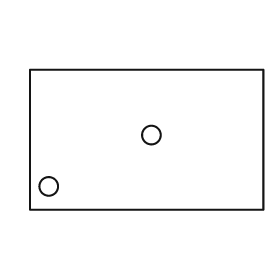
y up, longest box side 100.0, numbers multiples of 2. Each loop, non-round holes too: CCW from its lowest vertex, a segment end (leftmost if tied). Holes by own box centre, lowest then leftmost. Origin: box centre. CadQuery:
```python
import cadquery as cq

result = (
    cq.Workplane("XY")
    .moveTo(-50.0, -30.0)
    .lineTo(50.0, -30.0)
    .lineTo(50.0, 30.0)
    .lineTo(-50.0, 30.0)
    .close()
    .moveTo(-42.0, -20.0)
    .circle(4.0)
    .moveTo(2.0, 2.0)
    .circle(4.0)
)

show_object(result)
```